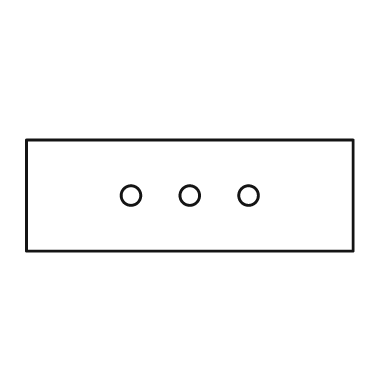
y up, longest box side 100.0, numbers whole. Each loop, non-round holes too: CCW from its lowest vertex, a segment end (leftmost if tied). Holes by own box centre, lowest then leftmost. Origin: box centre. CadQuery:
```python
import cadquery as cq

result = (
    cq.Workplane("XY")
    .moveTo(-50.0, -17.0)
    .lineTo(50.0, -17.0)
    .lineTo(50.0, 17.0)
    .lineTo(-50.0, 17.0)
    .close()
    .moveTo(-18.0, 0.0)
    .circle(3.0)
    .moveTo(0.0, 0.0)
    .circle(3.0)
    .moveTo(18.0, 0.0)
    .circle(3.0)
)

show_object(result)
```